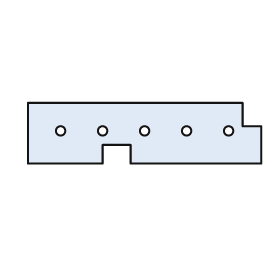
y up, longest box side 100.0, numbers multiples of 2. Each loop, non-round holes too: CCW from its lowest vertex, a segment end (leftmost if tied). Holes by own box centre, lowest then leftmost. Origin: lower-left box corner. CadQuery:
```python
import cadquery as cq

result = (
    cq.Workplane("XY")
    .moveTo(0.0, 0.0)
    .lineTo(32.0, 0.0)
    .lineTo(32.0, 8.0)
    .lineTo(44.0, 8.0)
    .lineTo(44.0, 0.0)
    .lineTo(100.0, 0.0)
    .lineTo(100.0, 16.0)
    .lineTo(92.0, 16.0)
    .lineTo(92.0, 26.0)
    .lineTo(0.0, 26.0)
    .close()
    .moveTo(14.0, 14.0)
    .circle(2.0)
    .moveTo(32.0, 14.0)
    .circle(2.0)
    .moveTo(50.0, 14.0)
    .circle(2.0)
    .moveTo(68.0, 14.0)
    .circle(2.0)
    .moveTo(86.0, 14.0)
    .circle(2.0)
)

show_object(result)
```